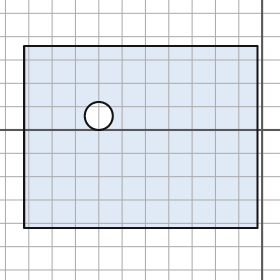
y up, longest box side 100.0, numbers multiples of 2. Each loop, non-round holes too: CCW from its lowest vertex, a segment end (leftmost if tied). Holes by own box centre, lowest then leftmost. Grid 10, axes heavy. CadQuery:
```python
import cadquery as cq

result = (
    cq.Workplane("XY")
    .moveTo(-102.0, -42.0)
    .lineTo(-2.0, -42.0)
    .lineTo(-2.0, 36.0)
    .lineTo(-102.0, 36.0)
    .close()
    .moveTo(-70.0, 6.0)
    .circle(6.0)
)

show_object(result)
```